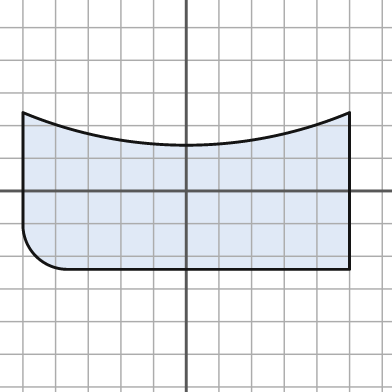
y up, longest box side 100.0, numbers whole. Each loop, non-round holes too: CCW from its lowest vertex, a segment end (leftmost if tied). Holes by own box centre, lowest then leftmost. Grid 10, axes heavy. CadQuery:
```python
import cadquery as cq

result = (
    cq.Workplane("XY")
    .moveTo(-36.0, -24.0)
    .lineTo(50.0, -24.0)
    .lineTo(50.0, 24.0)
    .threePointArc((0.0, 14.0), (-50.0, 24.0))
    .lineTo(-50.0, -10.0)
    .threePointArc((-46.0, -20.0), (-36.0, -24.0))
    .close()
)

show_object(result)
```